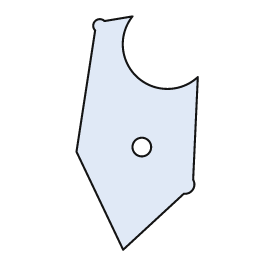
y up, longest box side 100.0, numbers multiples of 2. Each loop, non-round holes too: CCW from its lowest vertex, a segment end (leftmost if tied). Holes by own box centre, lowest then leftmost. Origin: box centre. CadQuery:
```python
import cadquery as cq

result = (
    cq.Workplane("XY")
    .moveTo(-6.0, -50.0)
    .lineTo(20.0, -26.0)
    .threePointArc((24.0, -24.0), (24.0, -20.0))
    .lineTo(26.0, 24.0)
    .threePointArc((0.0, 24.0), (-2.0, 50.0))
    .lineTo(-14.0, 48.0)
    .threePointArc((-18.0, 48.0), (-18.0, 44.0))
    .lineTo(-26.0, -8.0)
    .close()
    .moveTo(2.0, -6.0)
    .circle(4.0)
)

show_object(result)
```